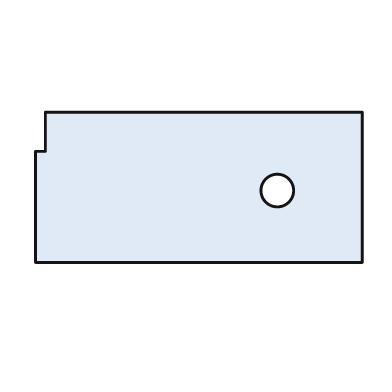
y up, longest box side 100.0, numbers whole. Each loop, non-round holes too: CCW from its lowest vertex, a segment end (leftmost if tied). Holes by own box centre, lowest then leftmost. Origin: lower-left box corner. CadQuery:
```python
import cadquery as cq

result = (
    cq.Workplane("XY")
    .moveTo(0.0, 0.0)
    .lineTo(100.0, 0.0)
    .lineTo(100.0, 46.0)
    .lineTo(3.0, 46.0)
    .lineTo(3.0, 34.0)
    .lineTo(0.0, 34.0)
    .close()
    .moveTo(74.0, 22.0)
    .circle(5.0)
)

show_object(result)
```